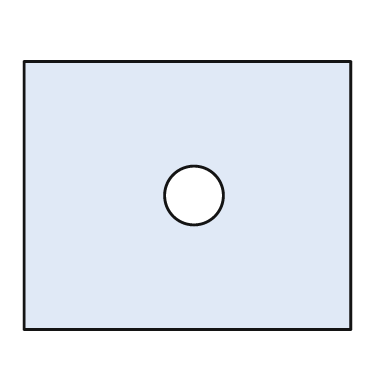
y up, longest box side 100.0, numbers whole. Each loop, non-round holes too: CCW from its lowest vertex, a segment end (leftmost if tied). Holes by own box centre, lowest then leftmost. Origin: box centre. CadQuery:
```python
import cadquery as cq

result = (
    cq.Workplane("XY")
    .moveTo(-50.0, -41.0)
    .lineTo(50.0, -41.0)
    .lineTo(50.0, 41.0)
    .lineTo(-50.0, 41.0)
    .close()
    .moveTo(2.0, 0.0)
    .circle(9.0)
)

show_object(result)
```